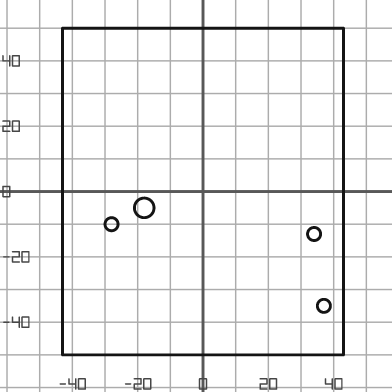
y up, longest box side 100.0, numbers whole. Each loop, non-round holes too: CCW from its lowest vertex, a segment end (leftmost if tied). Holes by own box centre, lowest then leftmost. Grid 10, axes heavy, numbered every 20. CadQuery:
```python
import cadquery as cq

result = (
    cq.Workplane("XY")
    .moveTo(-43.0, -50.0)
    .lineTo(43.0, -50.0)
    .lineTo(43.0, 50.0)
    .lineTo(-43.0, 50.0)
    .close()
    .moveTo(37.0, -35.0)
    .circle(2.0)
    .moveTo(34.0, -13.0)
    .circle(2.0)
    .moveTo(-28.0, -10.0)
    .circle(2.0)
    .moveTo(-18.0, -5.0)
    .circle(3.0)
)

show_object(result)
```